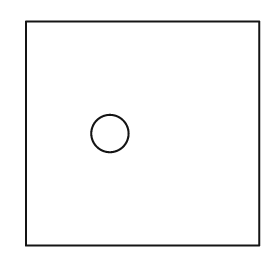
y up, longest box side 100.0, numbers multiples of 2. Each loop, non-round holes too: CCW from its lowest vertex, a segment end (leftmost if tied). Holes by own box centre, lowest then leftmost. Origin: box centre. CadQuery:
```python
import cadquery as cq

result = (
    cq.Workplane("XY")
    .moveTo(-50.0, -48.0)
    .lineTo(50.0, -48.0)
    .lineTo(50.0, 48.0)
    .lineTo(-50.0, 48.0)
    .close()
    .moveTo(-14.0, 0.0)
    .circle(8.0)
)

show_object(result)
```